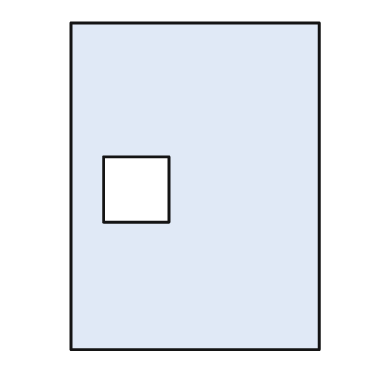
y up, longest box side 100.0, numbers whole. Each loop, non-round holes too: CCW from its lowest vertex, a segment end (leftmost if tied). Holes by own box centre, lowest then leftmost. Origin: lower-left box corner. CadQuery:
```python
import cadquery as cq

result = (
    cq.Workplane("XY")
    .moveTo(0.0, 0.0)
    .lineTo(76.0, 0.0)
    .lineTo(76.0, 100.0)
    .lineTo(0.0, 100.0)
    .close()
    .moveTo(10.0, 39.0)
    .lineTo(30.0, 39.0)
    .lineTo(30.0, 59.0)
    .lineTo(10.0, 59.0)
    .close()
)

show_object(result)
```